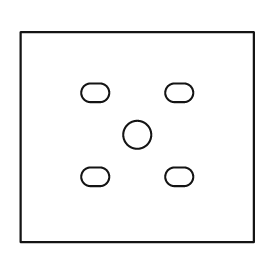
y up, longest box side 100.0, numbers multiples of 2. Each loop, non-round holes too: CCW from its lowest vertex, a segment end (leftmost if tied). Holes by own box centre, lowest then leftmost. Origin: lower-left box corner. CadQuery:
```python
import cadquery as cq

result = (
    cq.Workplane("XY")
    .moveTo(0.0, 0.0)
    .lineTo(100.0, 0.0)
    .lineTo(100.0, 90.0)
    .lineTo(0.0, 90.0)
    .close()
    .moveTo(30.0, 24.0)
    .lineTo(34.0, 24.0)
    .threePointArc((38.0, 28.0), (34.0, 32.0))
    .lineTo(30.0, 32.0)
    .threePointArc((26.0, 28.0), (30.0, 24.0))
    .close()
    .moveTo(66.0, 24.0)
    .lineTo(70.0, 24.0)
    .threePointArc((74.0, 28.0), (70.0, 32.0))
    .lineTo(66.0, 32.0)
    .threePointArc((62.0, 28.0), (66.0, 24.0))
    .close()
    .moveTo(50.0, 46.0)
    .circle(6.0)
    .moveTo(30.0, 60.0)
    .lineTo(34.0, 60.0)
    .threePointArc((38.0, 64.0), (34.0, 68.0))
    .lineTo(30.0, 68.0)
    .threePointArc((26.0, 64.0), (30.0, 60.0))
    .close()
    .moveTo(66.0, 60.0)
    .lineTo(70.0, 60.0)
    .threePointArc((74.0, 64.0), (70.0, 68.0))
    .lineTo(66.0, 68.0)
    .threePointArc((62.0, 64.0), (66.0, 60.0))
    .close()
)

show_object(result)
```